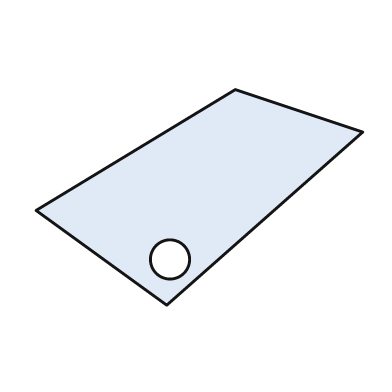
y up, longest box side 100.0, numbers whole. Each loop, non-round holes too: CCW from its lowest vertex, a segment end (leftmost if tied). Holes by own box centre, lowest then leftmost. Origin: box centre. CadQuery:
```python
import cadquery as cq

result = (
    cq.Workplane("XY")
    .moveTo(-10.0, -33.0)
    .lineTo(50.0, 20.0)
    .lineTo(11.0, 33.0)
    .lineTo(-50.0, -4.0)
    .close()
    .moveTo(-9.0, -19.0)
    .circle(6.0)
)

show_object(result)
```